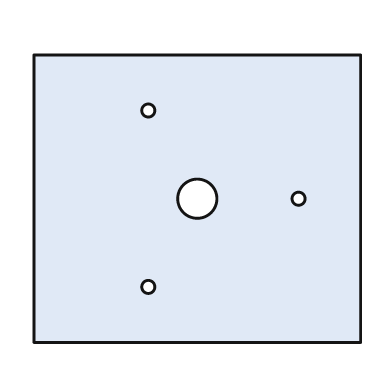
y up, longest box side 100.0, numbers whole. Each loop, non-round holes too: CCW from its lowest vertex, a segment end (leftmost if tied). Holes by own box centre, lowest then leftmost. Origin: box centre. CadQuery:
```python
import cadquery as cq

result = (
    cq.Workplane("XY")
    .moveTo(-50.0, -44.0)
    .lineTo(50.0, -44.0)
    .lineTo(50.0, 44.0)
    .lineTo(-50.0, 44.0)
    .close()
    .moveTo(-15.0, -27.0)
    .circle(2.0)
    .moveTo(0.0, 0.0)
    .circle(6.0)
    .moveTo(31.0, 0.0)
    .circle(2.0)
    .moveTo(-15.0, 27.0)
    .circle(2.0)
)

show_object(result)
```